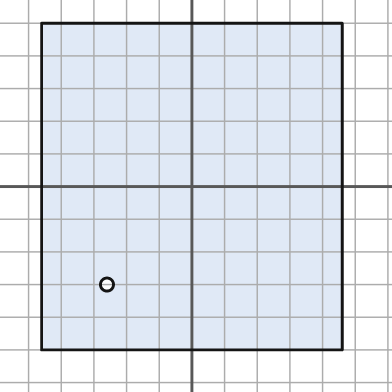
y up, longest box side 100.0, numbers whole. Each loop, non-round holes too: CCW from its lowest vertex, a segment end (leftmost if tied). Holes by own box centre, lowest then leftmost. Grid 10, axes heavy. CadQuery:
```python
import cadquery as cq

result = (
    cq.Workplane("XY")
    .moveTo(-46.0, -50.0)
    .lineTo(46.0, -50.0)
    .lineTo(46.0, 50.0)
    .lineTo(-46.0, 50.0)
    .close()
    .moveTo(-26.0, -30.0)
    .circle(2.0)
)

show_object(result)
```